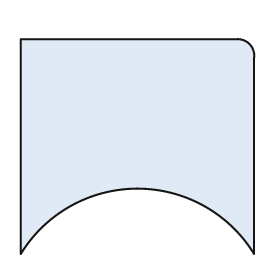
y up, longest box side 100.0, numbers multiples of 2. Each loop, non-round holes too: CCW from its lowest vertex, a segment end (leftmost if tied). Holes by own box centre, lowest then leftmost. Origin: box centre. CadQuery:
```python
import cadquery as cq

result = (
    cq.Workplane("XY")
    .moveTo(-50.0, -46.0)
    .threePointArc((0.0, -18.0), (50.0, -46.0))
    .lineTo(50.0, 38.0)
    .threePointArc((48.0, 44.0), (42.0, 46.0))
    .lineTo(-50.0, 46.0)
    .close()
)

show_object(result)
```